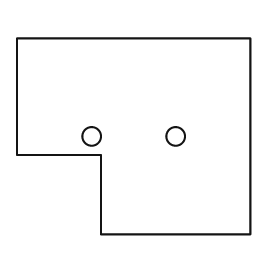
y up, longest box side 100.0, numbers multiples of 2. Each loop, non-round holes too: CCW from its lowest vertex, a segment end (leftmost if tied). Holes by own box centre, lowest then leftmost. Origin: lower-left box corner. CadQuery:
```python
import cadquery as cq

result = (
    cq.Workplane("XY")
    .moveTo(36.0, 0.0)
    .lineTo(100.0, 0.0)
    .lineTo(100.0, 84.0)
    .lineTo(0.0, 84.0)
    .lineTo(0.0, 34.0)
    .lineTo(36.0, 34.0)
    .close()
    .moveTo(32.0, 42.0)
    .circle(4.0)
    .moveTo(68.0, 42.0)
    .circle(4.0)
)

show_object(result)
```